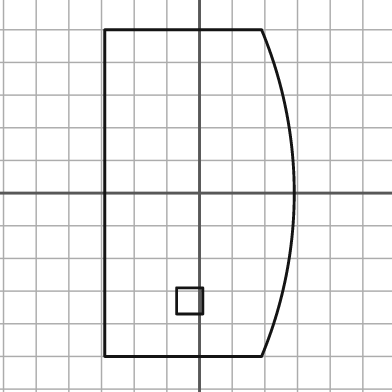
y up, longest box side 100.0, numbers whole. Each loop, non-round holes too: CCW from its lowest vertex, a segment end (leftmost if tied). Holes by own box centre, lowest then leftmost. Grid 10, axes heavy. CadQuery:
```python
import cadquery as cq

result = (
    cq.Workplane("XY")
    .moveTo(-29.0, -50.0)
    .lineTo(19.0, -50.0)
    .threePointArc((29.0, 0.0), (19.0, 50.0))
    .lineTo(-29.0, 50.0)
    .close()
    .moveTo(-7.0, -37.0)
    .lineTo(1.0, -37.0)
    .lineTo(1.0, -29.0)
    .lineTo(-7.0, -29.0)
    .close()
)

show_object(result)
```